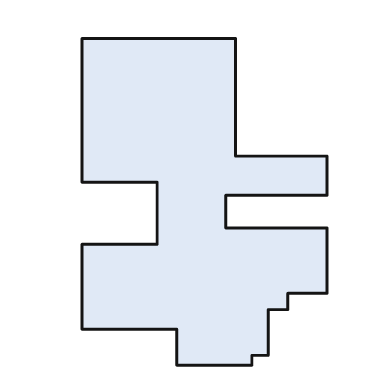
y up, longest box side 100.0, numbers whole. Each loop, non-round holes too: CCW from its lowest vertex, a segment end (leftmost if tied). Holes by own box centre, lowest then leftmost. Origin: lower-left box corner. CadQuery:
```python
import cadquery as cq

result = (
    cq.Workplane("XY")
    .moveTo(29.0, 0.0)
    .lineTo(52.0, 0.0)
    .lineTo(52.0, 3.0)
    .lineTo(57.0, 3.0)
    .lineTo(57.0, 17.0)
    .lineTo(63.0, 17.0)
    .lineTo(63.0, 22.0)
    .lineTo(75.0, 22.0)
    .lineTo(75.0, 42.0)
    .lineTo(44.0, 42.0)
    .lineTo(44.0, 52.0)
    .lineTo(75.0, 52.0)
    .lineTo(75.0, 64.0)
    .lineTo(47.0, 64.0)
    .lineTo(47.0, 100.0)
    .lineTo(0.0, 100.0)
    .lineTo(0.0, 56.0)
    .lineTo(23.0, 56.0)
    .lineTo(23.0, 37.0)
    .lineTo(0.0, 37.0)
    .lineTo(0.0, 11.0)
    .lineTo(29.0, 11.0)
    .close()
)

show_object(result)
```